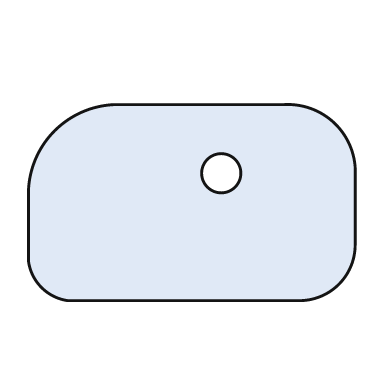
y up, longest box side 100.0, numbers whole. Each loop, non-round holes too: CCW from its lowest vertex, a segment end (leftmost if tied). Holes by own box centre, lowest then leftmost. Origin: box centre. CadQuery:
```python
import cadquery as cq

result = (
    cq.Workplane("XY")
    .moveTo(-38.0, -30.0)
    .lineTo(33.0, -30.0)
    .threePointArc((45.0, -25.0), (50.0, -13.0))
    .lineTo(50.0, 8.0)
    .threePointArc((44.0, 24.0), (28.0, 30.0))
    .lineTo(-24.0, 30.0)
    .threePointArc((-42.0, 22.0), (-50.0, 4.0))
    .lineTo(-50.0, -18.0)
    .threePointArc((-46.0, -26.0), (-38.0, -30.0))
    .close()
    .moveTo(9.0, 9.0)
    .circle(6.0)
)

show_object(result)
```